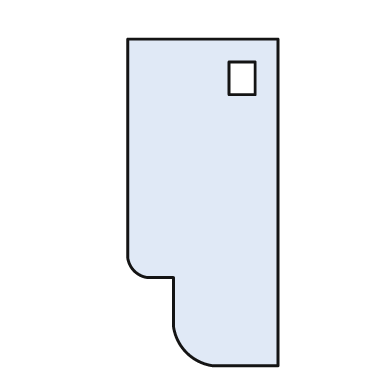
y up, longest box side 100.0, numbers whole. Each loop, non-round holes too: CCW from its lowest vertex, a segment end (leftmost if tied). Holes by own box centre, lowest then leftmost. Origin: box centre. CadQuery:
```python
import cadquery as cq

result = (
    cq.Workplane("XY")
    .moveTo(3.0, -50.0)
    .lineTo(23.0, -50.0)
    .lineTo(23.0, 50.0)
    .lineTo(-23.0, 50.0)
    .lineTo(-23.0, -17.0)
    .threePointArc((-21.0, -21.0), (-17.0, -23.0))
    .lineTo(-9.0, -23.0)
    .lineTo(-9.0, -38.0)
    .threePointArc((-5.0, -46.0), (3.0, -50.0))
    .close()
    .moveTo(8.0, 33.0)
    .lineTo(16.0, 33.0)
    .lineTo(16.0, 43.0)
    .lineTo(8.0, 43.0)
    .close()
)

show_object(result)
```